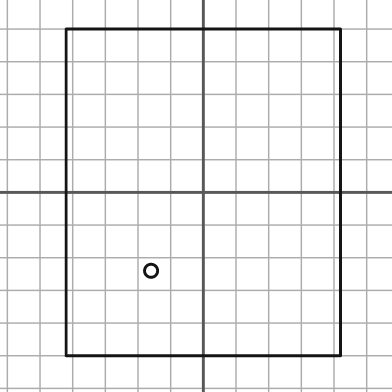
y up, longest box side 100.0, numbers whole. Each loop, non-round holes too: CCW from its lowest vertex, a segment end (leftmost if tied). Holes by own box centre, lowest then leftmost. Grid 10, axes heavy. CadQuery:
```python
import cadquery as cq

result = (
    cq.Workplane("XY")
    .moveTo(-42.0, -50.0)
    .lineTo(42.0, -50.0)
    .lineTo(42.0, 50.0)
    .lineTo(-42.0, 50.0)
    .close()
    .moveTo(-16.0, -24.0)
    .circle(2.0)
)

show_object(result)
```